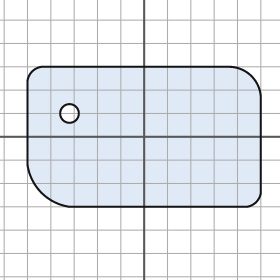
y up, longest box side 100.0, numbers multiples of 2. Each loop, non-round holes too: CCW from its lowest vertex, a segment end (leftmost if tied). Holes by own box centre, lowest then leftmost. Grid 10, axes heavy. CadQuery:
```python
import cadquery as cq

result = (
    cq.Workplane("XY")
    .moveTo(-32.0, -30.0)
    .lineTo(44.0, -30.0)
    .threePointArc((48.0, -28.0), (50.0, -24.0))
    .lineTo(50.0, 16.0)
    .threePointArc((46.0, 26.0), (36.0, 30.0))
    .lineTo(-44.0, 30.0)
    .threePointArc((-48.0, 28.0), (-50.0, 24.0))
    .lineTo(-50.0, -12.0)
    .threePointArc((-44.0, -24.0), (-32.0, -30.0))
    .close()
    .moveTo(-32.0, 10.0)
    .circle(4.0)
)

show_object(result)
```